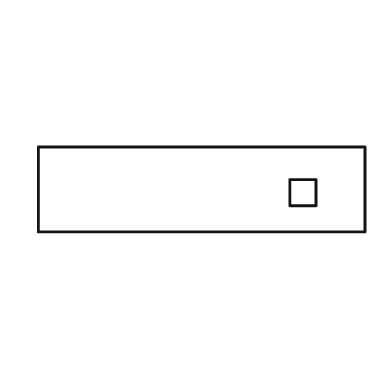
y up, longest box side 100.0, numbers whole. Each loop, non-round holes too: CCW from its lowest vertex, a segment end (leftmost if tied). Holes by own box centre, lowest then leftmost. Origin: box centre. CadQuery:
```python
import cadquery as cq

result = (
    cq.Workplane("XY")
    .moveTo(-50.0, -13.0)
    .lineTo(50.0, -13.0)
    .lineTo(50.0, 13.0)
    .lineTo(-50.0, 13.0)
    .close()
    .moveTo(27.0, -5.0)
    .lineTo(35.0, -5.0)
    .lineTo(35.0, 3.0)
    .lineTo(27.0, 3.0)
    .close()
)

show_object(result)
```